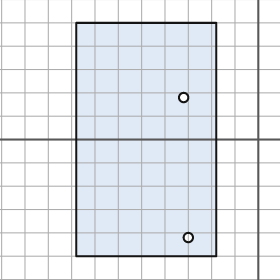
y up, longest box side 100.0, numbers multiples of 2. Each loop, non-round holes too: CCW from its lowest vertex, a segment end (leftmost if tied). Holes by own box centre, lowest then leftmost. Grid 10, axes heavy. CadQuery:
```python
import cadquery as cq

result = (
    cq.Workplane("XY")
    .moveTo(-78.0, -50.0)
    .lineTo(-18.0, -50.0)
    .lineTo(-18.0, 50.0)
    .lineTo(-78.0, 50.0)
    .close()
    .moveTo(-30.0, -42.0)
    .circle(2.0)
    .moveTo(-32.0, 18.0)
    .circle(2.0)
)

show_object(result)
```